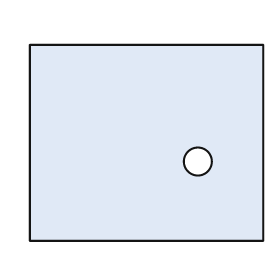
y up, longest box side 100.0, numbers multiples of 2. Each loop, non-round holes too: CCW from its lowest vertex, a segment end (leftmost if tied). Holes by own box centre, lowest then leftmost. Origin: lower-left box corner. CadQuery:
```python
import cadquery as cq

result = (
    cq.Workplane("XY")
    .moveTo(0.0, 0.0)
    .lineTo(100.0, 0.0)
    .lineTo(100.0, 84.0)
    .lineTo(0.0, 84.0)
    .close()
    .moveTo(72.0, 34.0)
    .circle(6.0)
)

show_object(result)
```